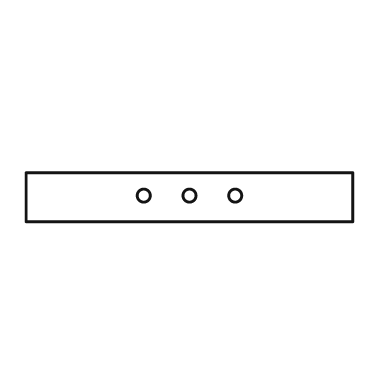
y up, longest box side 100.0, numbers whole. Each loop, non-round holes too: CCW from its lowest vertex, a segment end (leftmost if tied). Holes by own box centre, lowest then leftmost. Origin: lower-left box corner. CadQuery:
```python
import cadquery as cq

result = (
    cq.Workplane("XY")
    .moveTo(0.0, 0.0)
    .lineTo(100.0, 0.0)
    .lineTo(100.0, 15.0)
    .lineTo(0.0, 15.0)
    .close()
    .moveTo(36.0, 8.0)
    .circle(2.0)
    .moveTo(50.0, 8.0)
    .circle(2.0)
    .moveTo(64.0, 8.0)
    .circle(2.0)
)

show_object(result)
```